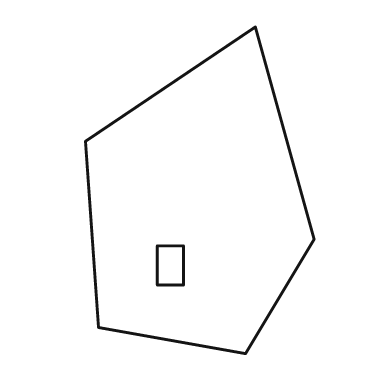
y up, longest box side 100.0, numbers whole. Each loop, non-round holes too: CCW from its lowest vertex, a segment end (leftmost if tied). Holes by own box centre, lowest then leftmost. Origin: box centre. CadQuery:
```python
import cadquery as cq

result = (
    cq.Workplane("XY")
    .moveTo(14.0, -50.0)
    .lineTo(35.0, -15.0)
    .lineTo(17.0, 50.0)
    .lineTo(-35.0, 15.0)
    .lineTo(-31.0, -42.0)
    .close()
    .moveTo(-13.0, -29.0)
    .lineTo(-5.0, -29.0)
    .lineTo(-5.0, -17.0)
    .lineTo(-13.0, -17.0)
    .close()
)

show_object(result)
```